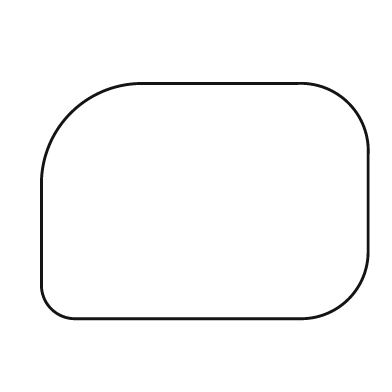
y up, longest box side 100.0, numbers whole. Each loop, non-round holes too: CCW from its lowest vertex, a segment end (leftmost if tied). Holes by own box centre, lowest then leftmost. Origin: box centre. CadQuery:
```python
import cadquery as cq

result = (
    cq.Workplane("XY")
    .moveTo(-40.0, -36.0)
    .lineTo(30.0, -36.0)
    .threePointArc((44.0, -30.0), (50.0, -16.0))
    .lineTo(50.0, 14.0)
    .threePointArc((44.0, 30.0), (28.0, 36.0))
    .lineTo(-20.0, 36.0)
    .threePointArc((-41.0, 27.0), (-50.0, 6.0))
    .lineTo(-50.0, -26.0)
    .threePointArc((-47.0, -33.0), (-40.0, -36.0))
    .close()
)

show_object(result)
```